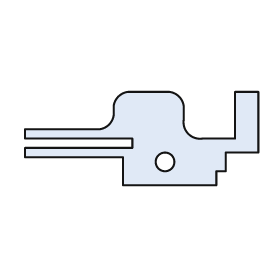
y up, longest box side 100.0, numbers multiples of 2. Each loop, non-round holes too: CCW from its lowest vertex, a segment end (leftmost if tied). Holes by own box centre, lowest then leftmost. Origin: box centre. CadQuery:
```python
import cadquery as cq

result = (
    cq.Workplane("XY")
    .moveTo(-8.0, -20.0)
    .lineTo(32.0, -20.0)
    .lineTo(32.0, -14.0)
    .lineTo(36.0, -14.0)
    .lineTo(36.0, -6.0)
    .lineTo(50.0, -6.0)
    .lineTo(50.0, 20.0)
    .lineTo(40.0, 20.0)
    .lineTo(40.0, 0.0)
    .lineTo(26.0, 0.0)
    .threePointArc((20.0, 2.0), (18.0, 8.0))
    .lineTo(18.0, 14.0)
    .threePointArc((16.0, 18.0), (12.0, 20.0))
    .lineTo(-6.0, 20.0)
    .threePointArc((-10.0, 18.0), (-12.0, 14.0))
    .lineTo(-12.0, 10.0)
    .threePointArc((-14.0, 6.0), (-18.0, 4.0))
    .lineTo(-50.0, 4.0)
    .lineTo(-50.0, 0.0)
    .lineTo(-4.0, 0.0)
    .lineTo(-4.0, -4.0)
    .lineTo(-50.0, -4.0)
    .lineTo(-50.0, -8.0)
    .lineTo(-8.0, -8.0)
    .close()
    .moveTo(10.0, -10.0)
    .circle(4.0)
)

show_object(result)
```